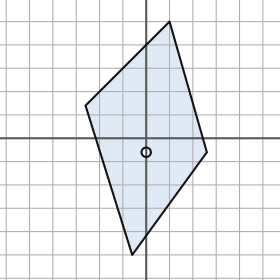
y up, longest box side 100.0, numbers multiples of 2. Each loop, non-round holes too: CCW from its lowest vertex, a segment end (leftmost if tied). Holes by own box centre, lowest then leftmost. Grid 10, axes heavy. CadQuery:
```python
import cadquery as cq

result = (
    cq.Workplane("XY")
    .moveTo(-6.0, -50.0)
    .lineTo(26.0, -6.0)
    .lineTo(10.0, 50.0)
    .lineTo(-26.0, 14.0)
    .close()
    .moveTo(0.0, -6.0)
    .circle(2.0)
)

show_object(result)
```